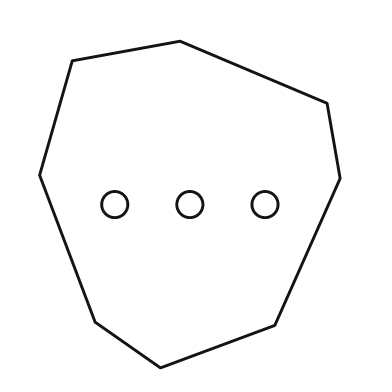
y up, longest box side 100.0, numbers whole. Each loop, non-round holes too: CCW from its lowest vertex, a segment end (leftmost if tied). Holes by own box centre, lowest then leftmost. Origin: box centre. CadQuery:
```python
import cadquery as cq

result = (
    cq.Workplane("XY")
    .moveTo(-9.0, -50.0)
    .lineTo(26.0, -37.0)
    .lineTo(46.0, 8.0)
    .lineTo(42.0, 31.0)
    .lineTo(-3.0, 50.0)
    .lineTo(-36.0, 44.0)
    .lineTo(-46.0, 9.0)
    .lineTo(-29.0, -36.0)
    .close()
    .moveTo(-23.0, 0.0)
    .circle(4.0)
    .moveTo(0.0, 0.0)
    .circle(4.0)
    .moveTo(23.0, 0.0)
    .circle(4.0)
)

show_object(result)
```